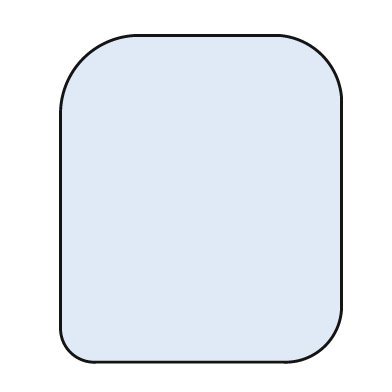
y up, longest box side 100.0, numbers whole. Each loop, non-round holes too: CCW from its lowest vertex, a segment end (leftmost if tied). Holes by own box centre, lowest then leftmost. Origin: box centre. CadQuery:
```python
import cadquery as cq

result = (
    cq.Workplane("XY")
    .moveTo(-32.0, -50.0)
    .lineTo(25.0, -50.0)
    .threePointArc((38.0, -45.0), (43.0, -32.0))
    .lineTo(43.0, 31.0)
    .threePointArc((37.0, 44.0), (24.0, 50.0))
    .lineTo(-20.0, 50.0)
    .threePointArc((-36.0, 43.0), (-43.0, 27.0))
    .lineTo(-43.0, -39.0)
    .threePointArc((-40.0, -47.0), (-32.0, -50.0))
    .close()
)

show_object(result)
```